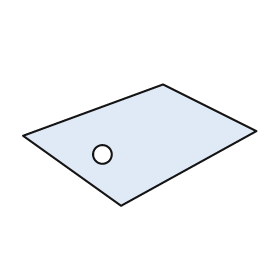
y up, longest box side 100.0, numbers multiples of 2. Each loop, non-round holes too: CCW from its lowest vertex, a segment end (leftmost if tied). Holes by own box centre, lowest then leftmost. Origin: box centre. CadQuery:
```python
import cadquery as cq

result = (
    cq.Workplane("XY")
    .moveTo(-8.0, -26.0)
    .lineTo(50.0, 6.0)
    .lineTo(10.0, 26.0)
    .lineTo(-50.0, 4.0)
    .close()
    .moveTo(-16.0, -4.0)
    .circle(4.0)
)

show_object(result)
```